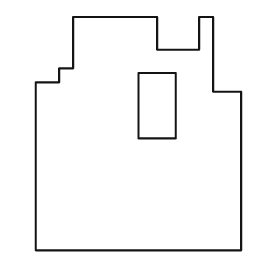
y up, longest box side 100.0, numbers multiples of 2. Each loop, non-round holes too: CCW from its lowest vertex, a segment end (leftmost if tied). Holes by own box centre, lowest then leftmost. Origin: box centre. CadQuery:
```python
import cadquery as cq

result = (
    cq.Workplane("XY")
    .moveTo(-44.0, -50.0)
    .lineTo(44.0, -50.0)
    .lineTo(44.0, 18.0)
    .lineTo(32.0, 18.0)
    .lineTo(32.0, 50.0)
    .lineTo(26.0, 50.0)
    .lineTo(26.0, 36.0)
    .lineTo(8.0, 36.0)
    .lineTo(8.0, 50.0)
    .lineTo(-28.0, 50.0)
    .lineTo(-28.0, 28.0)
    .lineTo(-34.0, 28.0)
    .lineTo(-34.0, 22.0)
    .lineTo(-44.0, 22.0)
    .close()
    .moveTo(0.0, -2.0)
    .lineTo(16.0, -2.0)
    .lineTo(16.0, 26.0)
    .lineTo(0.0, 26.0)
    .close()
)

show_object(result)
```